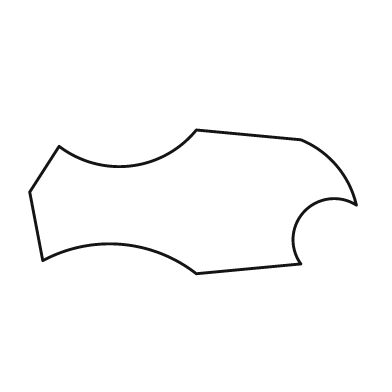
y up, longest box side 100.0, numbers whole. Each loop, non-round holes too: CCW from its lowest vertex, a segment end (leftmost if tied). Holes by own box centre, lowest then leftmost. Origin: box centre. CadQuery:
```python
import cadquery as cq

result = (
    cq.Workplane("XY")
    .moveTo(1.0, -22.0)
    .lineTo(33.0, -19.0)
    .threePointArc((34.0, -3.0), (50.0, -1.0))
    .threePointArc((44.0, 11.0), (33.0, 19.0))
    .lineTo(1.0, 22.0)
    .threePointArc((-19.0, 11.0), (-41.0, 17.0))
    .lineTo(-50.0, 3.0)
    .lineTo(-46.0, -18.0)
    .threePointArc((-22.0, -13.0), (1.0, -22.0))
    .close()
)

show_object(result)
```